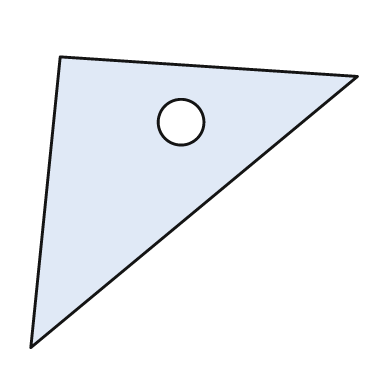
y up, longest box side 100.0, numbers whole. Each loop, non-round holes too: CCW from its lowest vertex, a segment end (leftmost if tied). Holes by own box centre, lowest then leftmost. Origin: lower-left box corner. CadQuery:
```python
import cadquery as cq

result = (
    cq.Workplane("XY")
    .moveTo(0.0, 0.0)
    .lineTo(100.0, 83.0)
    .lineTo(9.0, 89.0)
    .close()
    .moveTo(46.0, 69.0)
    .circle(7.0)
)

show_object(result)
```